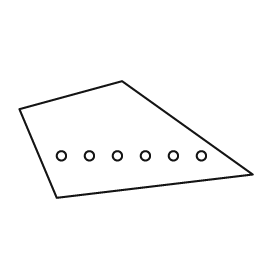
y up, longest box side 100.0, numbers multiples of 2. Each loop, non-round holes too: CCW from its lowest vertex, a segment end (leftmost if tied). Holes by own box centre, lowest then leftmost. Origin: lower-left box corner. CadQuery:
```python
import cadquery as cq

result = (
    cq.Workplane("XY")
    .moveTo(16.0, 0.0)
    .lineTo(100.0, 10.0)
    .lineTo(44.0, 50.0)
    .lineTo(0.0, 38.0)
    .close()
    .moveTo(18.0, 18.0)
    .circle(2.0)
    .moveTo(30.0, 18.0)
    .circle(2.0)
    .moveTo(42.0, 18.0)
    .circle(2.0)
    .moveTo(54.0, 18.0)
    .circle(2.0)
    .moveTo(66.0, 18.0)
    .circle(2.0)
    .moveTo(78.0, 18.0)
    .circle(2.0)
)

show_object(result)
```